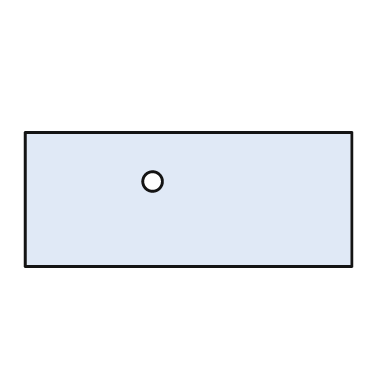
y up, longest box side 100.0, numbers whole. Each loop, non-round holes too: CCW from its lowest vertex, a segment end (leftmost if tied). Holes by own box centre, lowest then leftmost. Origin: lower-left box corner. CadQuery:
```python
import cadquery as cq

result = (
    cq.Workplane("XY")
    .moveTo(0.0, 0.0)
    .lineTo(100.0, 0.0)
    .lineTo(100.0, 41.0)
    .lineTo(0.0, 41.0)
    .close()
    .moveTo(39.0, 26.0)
    .circle(3.0)
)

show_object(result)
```